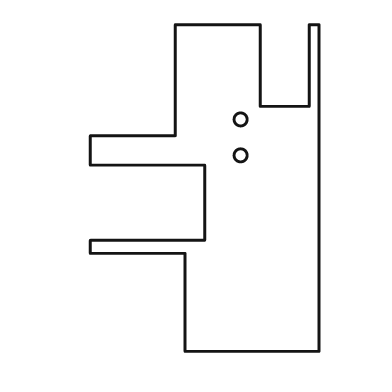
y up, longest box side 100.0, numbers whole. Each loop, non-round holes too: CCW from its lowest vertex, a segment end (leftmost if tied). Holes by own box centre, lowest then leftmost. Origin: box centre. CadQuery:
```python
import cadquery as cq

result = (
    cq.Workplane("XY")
    .moveTo(-6.0, -50.0)
    .lineTo(35.0, -50.0)
    .lineTo(35.0, 50.0)
    .lineTo(32.0, 50.0)
    .lineTo(32.0, 25.0)
    .lineTo(17.0, 25.0)
    .lineTo(17.0, 50.0)
    .lineTo(-9.0, 50.0)
    .lineTo(-9.0, 16.0)
    .lineTo(-35.0, 16.0)
    .lineTo(-35.0, 7.0)
    .lineTo(0.0, 7.0)
    .lineTo(0.0, -16.0)
    .lineTo(-35.0, -16.0)
    .lineTo(-35.0, -20.0)
    .lineTo(-6.0, -20.0)
    .close()
    .moveTo(11.0, 10.0)
    .circle(2.0)
    .moveTo(11.0, 21.0)
    .circle(2.0)
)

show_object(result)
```